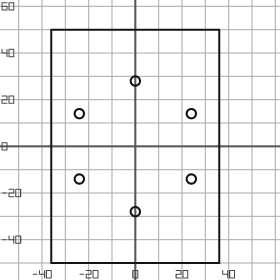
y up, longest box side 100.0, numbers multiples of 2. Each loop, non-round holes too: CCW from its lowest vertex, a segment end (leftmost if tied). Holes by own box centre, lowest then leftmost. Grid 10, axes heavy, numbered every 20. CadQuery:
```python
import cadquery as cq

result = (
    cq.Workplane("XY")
    .moveTo(-36.0, -50.0)
    .lineTo(36.0, -50.0)
    .lineTo(36.0, 50.0)
    .lineTo(-36.0, 50.0)
    .close()
    .moveTo(0.0, -28.0)
    .circle(2.0)
    .moveTo(-24.0, -14.0)
    .circle(2.0)
    .moveTo(24.0, -14.0)
    .circle(2.0)
    .moveTo(-24.0, 14.0)
    .circle(2.0)
    .moveTo(24.0, 14.0)
    .circle(2.0)
    .moveTo(0.0, 28.0)
    .circle(2.0)
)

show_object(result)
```